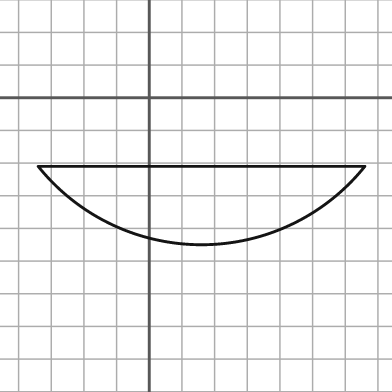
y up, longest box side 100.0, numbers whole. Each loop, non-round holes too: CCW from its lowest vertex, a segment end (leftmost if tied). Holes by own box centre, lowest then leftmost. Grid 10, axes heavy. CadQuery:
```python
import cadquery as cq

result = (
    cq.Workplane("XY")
    .moveTo(-34.0, -21.0)
    .threePointArc((16.0, -45.0), (66.0, -21.0))
    .close()
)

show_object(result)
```